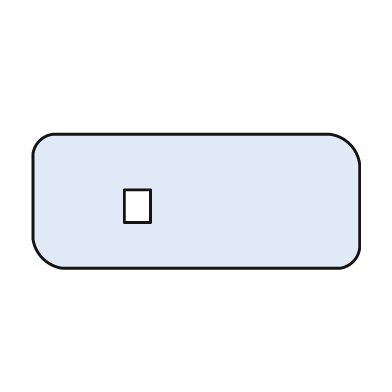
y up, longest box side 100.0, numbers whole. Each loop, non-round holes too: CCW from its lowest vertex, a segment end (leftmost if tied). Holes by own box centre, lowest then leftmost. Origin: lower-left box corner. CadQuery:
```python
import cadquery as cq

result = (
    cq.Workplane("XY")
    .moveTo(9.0, 0.0)
    .lineTo(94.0, 0.0)
    .threePointArc((98.0, 2.0), (100.0, 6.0))
    .lineTo(100.0, 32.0)
    .threePointArc((97.0, 38.0), (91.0, 41.0))
    .lineTo(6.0, 41.0)
    .threePointArc((2.0, 39.0), (0.0, 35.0))
    .lineTo(0.0, 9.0)
    .threePointArc((3.0, 3.0), (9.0, 0.0))
    .close()
    .moveTo(28.0, 14.0)
    .lineTo(36.0, 14.0)
    .lineTo(36.0, 24.0)
    .lineTo(28.0, 24.0)
    .close()
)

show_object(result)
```